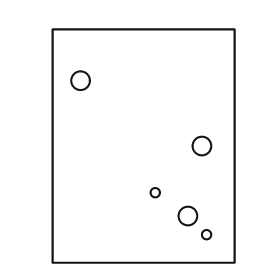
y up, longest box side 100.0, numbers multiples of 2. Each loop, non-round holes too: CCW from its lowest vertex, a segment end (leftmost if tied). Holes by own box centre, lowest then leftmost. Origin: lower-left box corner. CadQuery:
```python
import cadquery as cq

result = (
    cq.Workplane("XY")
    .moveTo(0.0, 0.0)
    .lineTo(78.0, 0.0)
    .lineTo(78.0, 100.0)
    .lineTo(0.0, 100.0)
    .close()
    .moveTo(66.0, 12.0)
    .circle(2.0)
    .moveTo(58.0, 20.0)
    .circle(4.0)
    .moveTo(44.0, 30.0)
    .circle(2.0)
    .moveTo(64.0, 50.0)
    .circle(4.0)
    .moveTo(12.0, 78.0)
    .circle(4.0)
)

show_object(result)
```